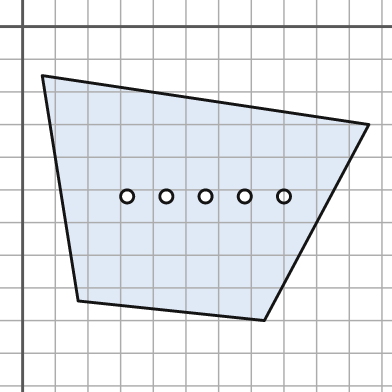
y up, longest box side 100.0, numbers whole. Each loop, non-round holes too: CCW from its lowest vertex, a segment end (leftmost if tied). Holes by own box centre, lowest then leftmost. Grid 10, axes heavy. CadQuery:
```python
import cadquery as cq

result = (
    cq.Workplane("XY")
    .moveTo(74.0, -90.0)
    .lineTo(106.0, -30.0)
    .lineTo(6.0, -15.0)
    .lineTo(17.0, -84.0)
    .close()
    .moveTo(32.0, -52.0)
    .circle(2.0)
    .moveTo(44.0, -52.0)
    .circle(2.0)
    .moveTo(56.0, -52.0)
    .circle(2.0)
    .moveTo(68.0, -52.0)
    .circle(2.0)
    .moveTo(80.0, -52.0)
    .circle(2.0)
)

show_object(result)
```